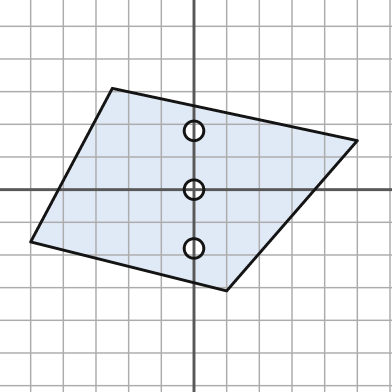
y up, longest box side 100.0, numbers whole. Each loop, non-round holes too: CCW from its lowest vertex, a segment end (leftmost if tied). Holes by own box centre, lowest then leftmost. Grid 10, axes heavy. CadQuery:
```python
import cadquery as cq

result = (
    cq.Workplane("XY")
    .moveTo(10.0, -31.0)
    .lineTo(50.0, 15.0)
    .lineTo(-25.0, 31.0)
    .lineTo(-50.0, -16.0)
    .close()
    .moveTo(0.0, -18.0)
    .circle(3.0)
    .moveTo(0.0, 0.0)
    .circle(3.0)
    .moveTo(0.0, 18.0)
    .circle(3.0)
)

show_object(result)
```